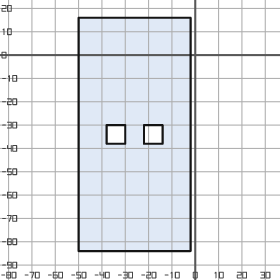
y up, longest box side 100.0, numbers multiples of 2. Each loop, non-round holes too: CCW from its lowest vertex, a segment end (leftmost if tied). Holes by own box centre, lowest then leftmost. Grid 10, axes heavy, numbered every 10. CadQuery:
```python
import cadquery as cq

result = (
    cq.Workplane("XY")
    .moveTo(-50.0, -84.0)
    .lineTo(-2.0, -84.0)
    .lineTo(-2.0, 16.0)
    .lineTo(-50.0, 16.0)
    .close()
    .moveTo(-38.0, -38.0)
    .lineTo(-30.0, -38.0)
    .lineTo(-30.0, -30.0)
    .lineTo(-38.0, -30.0)
    .close()
    .moveTo(-22.0, -38.0)
    .lineTo(-14.0, -38.0)
    .lineTo(-14.0, -30.0)
    .lineTo(-22.0, -30.0)
    .close()
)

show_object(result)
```